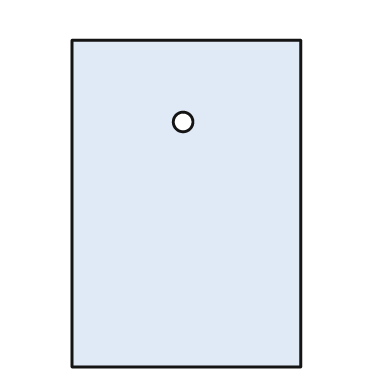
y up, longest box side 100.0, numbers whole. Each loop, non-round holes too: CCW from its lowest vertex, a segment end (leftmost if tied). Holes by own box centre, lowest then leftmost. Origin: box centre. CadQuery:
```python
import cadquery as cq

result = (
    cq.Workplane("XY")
    .moveTo(-35.0, -50.0)
    .lineTo(35.0, -50.0)
    .lineTo(35.0, 50.0)
    .lineTo(-35.0, 50.0)
    .close()
    .moveTo(-1.0, 25.0)
    .circle(3.0)
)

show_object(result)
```